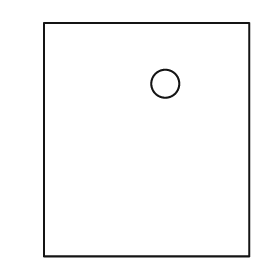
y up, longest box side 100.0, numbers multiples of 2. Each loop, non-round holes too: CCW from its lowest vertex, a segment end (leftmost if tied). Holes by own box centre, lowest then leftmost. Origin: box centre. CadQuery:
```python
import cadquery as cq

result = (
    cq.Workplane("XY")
    .moveTo(-44.0, -50.0)
    .lineTo(44.0, -50.0)
    .lineTo(44.0, 50.0)
    .lineTo(-44.0, 50.0)
    .close()
    .moveTo(8.0, 24.0)
    .circle(6.0)
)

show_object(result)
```